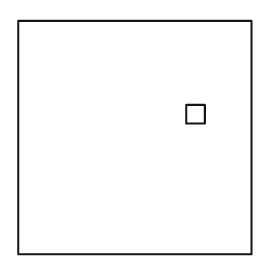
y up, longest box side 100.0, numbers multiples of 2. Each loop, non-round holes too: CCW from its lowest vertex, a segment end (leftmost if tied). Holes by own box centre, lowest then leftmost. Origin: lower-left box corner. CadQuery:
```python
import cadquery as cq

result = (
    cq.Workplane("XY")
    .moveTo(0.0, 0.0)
    .lineTo(100.0, 0.0)
    .lineTo(100.0, 100.0)
    .lineTo(0.0, 100.0)
    .close()
    .moveTo(72.0, 56.0)
    .lineTo(80.0, 56.0)
    .lineTo(80.0, 64.0)
    .lineTo(72.0, 64.0)
    .close()
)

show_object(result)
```